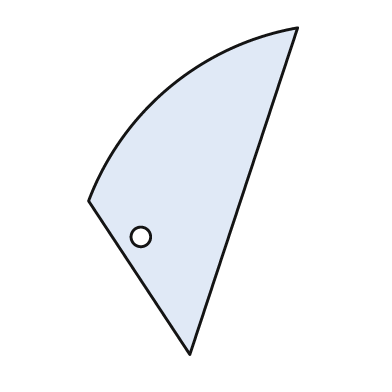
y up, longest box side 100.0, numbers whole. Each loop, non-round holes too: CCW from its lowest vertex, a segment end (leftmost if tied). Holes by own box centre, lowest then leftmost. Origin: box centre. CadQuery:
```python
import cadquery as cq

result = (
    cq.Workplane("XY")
    .moveTo(-1.0, -50.0)
    .lineTo(32.0, 50.0)
    .threePointArc((-7.0, 32.0), (-32.0, -3.0))
    .close()
    .moveTo(-16.0, -14.0)
    .circle(3.0)
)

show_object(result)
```